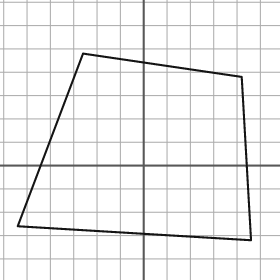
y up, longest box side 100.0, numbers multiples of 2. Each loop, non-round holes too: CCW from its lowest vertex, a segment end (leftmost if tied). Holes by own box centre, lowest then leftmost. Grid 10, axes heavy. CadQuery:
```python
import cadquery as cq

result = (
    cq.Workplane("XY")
    .moveTo(46.0, -32.0)
    .lineTo(42.0, 38.0)
    .lineTo(-26.0, 48.0)
    .lineTo(-54.0, -26.0)
    .close()
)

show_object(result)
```